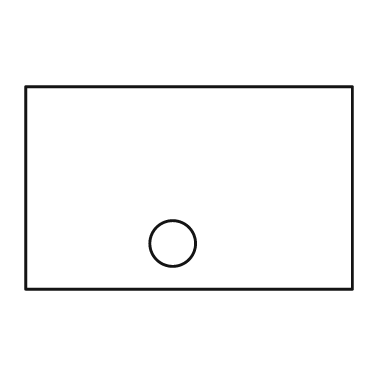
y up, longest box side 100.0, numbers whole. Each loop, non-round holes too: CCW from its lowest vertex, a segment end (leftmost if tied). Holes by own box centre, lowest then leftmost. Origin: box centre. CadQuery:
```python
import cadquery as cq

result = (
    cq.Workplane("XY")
    .moveTo(-50.0, -31.0)
    .lineTo(50.0, -31.0)
    .lineTo(50.0, 31.0)
    .lineTo(-50.0, 31.0)
    .close()
    .moveTo(-5.0, -17.0)
    .circle(7.0)
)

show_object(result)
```